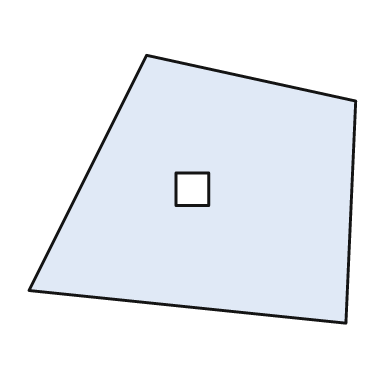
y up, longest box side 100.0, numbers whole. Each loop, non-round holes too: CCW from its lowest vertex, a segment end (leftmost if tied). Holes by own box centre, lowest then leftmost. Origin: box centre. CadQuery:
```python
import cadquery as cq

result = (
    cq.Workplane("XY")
    .moveTo(47.0, -41.0)
    .lineTo(50.0, 27.0)
    .lineTo(-14.0, 41.0)
    .lineTo(-50.0, -31.0)
    .close()
    .moveTo(-5.0, -5.0)
    .lineTo(5.0, -5.0)
    .lineTo(5.0, 5.0)
    .lineTo(-5.0, 5.0)
    .close()
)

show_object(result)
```